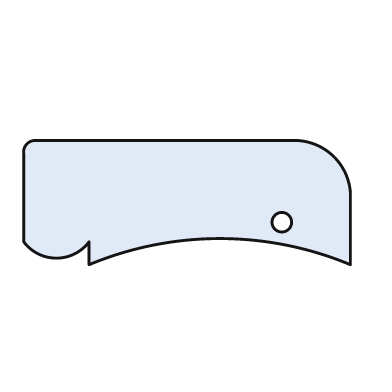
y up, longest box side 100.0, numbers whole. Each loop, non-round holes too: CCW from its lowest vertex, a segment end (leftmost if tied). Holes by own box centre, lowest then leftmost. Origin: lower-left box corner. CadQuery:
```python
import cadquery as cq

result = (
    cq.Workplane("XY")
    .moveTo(20.0, 0.0)
    .threePointArc((60.0, 8.0), (100.0, 0.0))
    .lineTo(100.0, 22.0)
    .threePointArc((95.0, 33.0), (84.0, 38.0))
    .lineTo(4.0, 38.0)
    .threePointArc((1.0, 37.0), (0.0, 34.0))
    .lineTo(0.0, 7.0)
    .threePointArc((10.0, 2.0), (20.0, 7.0))
    .close()
    .moveTo(79.0, 13.0)
    .circle(3.0)
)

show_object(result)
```